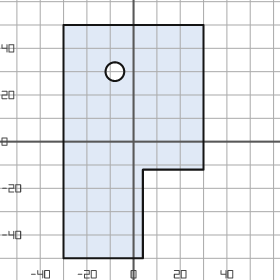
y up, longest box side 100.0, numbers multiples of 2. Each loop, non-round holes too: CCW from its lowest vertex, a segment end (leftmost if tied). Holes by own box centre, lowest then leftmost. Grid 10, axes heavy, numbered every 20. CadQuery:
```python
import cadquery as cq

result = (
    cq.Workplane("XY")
    .moveTo(-30.0, -50.0)
    .lineTo(4.0, -50.0)
    .lineTo(4.0, -12.0)
    .lineTo(30.0, -12.0)
    .lineTo(30.0, 50.0)
    .lineTo(-30.0, 50.0)
    .close()
    .moveTo(-8.0, 30.0)
    .circle(4.0)
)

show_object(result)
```